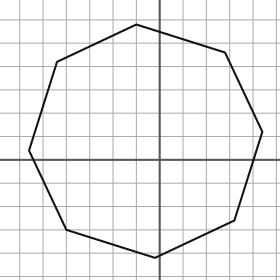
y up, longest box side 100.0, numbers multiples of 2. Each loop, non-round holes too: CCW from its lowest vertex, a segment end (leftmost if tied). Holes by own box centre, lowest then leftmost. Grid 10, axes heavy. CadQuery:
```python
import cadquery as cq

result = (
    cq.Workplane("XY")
    .moveTo(-2.0, -42.0)
    .lineTo(32.0, -26.0)
    .lineTo(44.0, 12.0)
    .lineTo(28.0, 46.0)
    .lineTo(-10.0, 58.0)
    .lineTo(-44.0, 42.0)
    .lineTo(-56.0, 4.0)
    .lineTo(-40.0, -30.0)
    .close()
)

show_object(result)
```